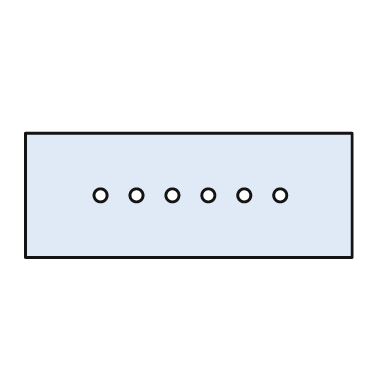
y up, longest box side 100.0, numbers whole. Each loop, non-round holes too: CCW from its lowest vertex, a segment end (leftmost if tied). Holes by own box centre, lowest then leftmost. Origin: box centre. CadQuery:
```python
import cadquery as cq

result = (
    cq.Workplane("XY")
    .moveTo(-50.0, -19.0)
    .lineTo(50.0, -19.0)
    .lineTo(50.0, 19.0)
    .lineTo(-50.0, 19.0)
    .close()
    .moveTo(-27.0, 0.0)
    .circle(2.0)
    .moveTo(-16.0, 0.0)
    .circle(2.0)
    .moveTo(-5.0, 0.0)
    .circle(2.0)
    .moveTo(6.0, 0.0)
    .circle(2.0)
    .moveTo(17.0, 0.0)
    .circle(2.0)
    .moveTo(28.0, 0.0)
    .circle(2.0)
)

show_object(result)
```